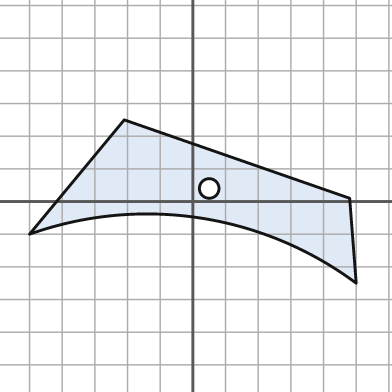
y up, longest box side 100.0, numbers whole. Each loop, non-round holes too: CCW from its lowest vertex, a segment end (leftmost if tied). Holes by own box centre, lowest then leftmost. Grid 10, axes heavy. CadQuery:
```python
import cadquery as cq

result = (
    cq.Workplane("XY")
    .moveTo(50.0, -25.0)
    .lineTo(48.0, 1.0)
    .lineTo(-21.0, 25.0)
    .lineTo(-50.0, -10.0)
    .threePointArc((2.0, -5.0), (50.0, -25.0))
    .close()
    .moveTo(5.0, 4.0)
    .circle(3.0)
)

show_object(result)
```